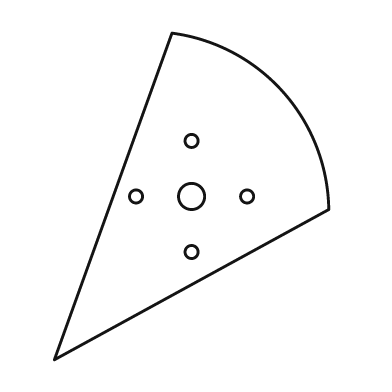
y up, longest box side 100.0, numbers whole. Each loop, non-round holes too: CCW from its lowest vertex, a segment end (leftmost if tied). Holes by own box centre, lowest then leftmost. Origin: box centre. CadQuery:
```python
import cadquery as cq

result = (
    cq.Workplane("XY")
    .moveTo(-42.0, -50.0)
    .lineTo(42.0, -4.0)
    .threePointArc((28.0, 32.0), (-6.0, 50.0))
    .close()
    .moveTo(0.0, -17.0)
    .circle(2.0)
    .moveTo(-17.0, 0.0)
    .circle(2.0)
    .moveTo(0.0, 0.0)
    .circle(4.0)
    .moveTo(17.0, 0.0)
    .circle(2.0)
    .moveTo(0.0, 17.0)
    .circle(2.0)
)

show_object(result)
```